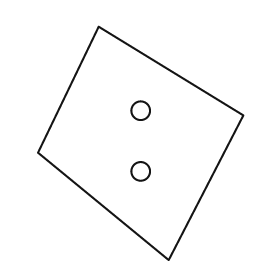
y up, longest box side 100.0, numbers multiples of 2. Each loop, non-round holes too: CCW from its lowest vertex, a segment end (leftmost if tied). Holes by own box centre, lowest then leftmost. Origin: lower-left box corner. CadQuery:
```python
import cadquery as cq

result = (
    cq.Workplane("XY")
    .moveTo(56.0, 0.0)
    .lineTo(88.0, 62.0)
    .lineTo(26.0, 100.0)
    .lineTo(0.0, 46.0)
    .close()
    .moveTo(44.0, 38.0)
    .circle(4.0)
    .moveTo(44.0, 64.0)
    .circle(4.0)
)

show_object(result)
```